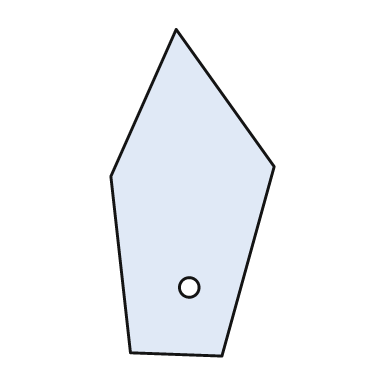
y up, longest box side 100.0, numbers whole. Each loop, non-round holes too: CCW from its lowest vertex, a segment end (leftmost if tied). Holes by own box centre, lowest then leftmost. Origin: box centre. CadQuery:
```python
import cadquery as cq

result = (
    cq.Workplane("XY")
    .moveTo(9.0, -50.0)
    .lineTo(25.0, 8.0)
    .lineTo(-5.0, 50.0)
    .lineTo(-25.0, 5.0)
    .lineTo(-19.0, -49.0)
    .close()
    .moveTo(-1.0, -29.0)
    .circle(3.0)
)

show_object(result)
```